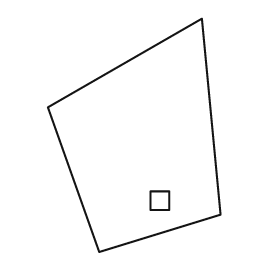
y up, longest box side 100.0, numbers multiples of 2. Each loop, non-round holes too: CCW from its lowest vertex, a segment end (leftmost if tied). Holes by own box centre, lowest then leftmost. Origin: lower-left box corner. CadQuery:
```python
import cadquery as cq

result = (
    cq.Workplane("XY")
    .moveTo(22.0, 0.0)
    .lineTo(74.0, 16.0)
    .lineTo(66.0, 100.0)
    .lineTo(0.0, 62.0)
    .close()
    .moveTo(44.0, 18.0)
    .lineTo(52.0, 18.0)
    .lineTo(52.0, 26.0)
    .lineTo(44.0, 26.0)
    .close()
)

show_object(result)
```